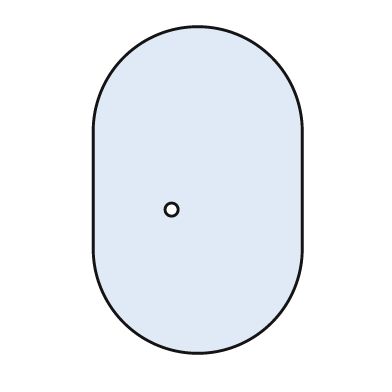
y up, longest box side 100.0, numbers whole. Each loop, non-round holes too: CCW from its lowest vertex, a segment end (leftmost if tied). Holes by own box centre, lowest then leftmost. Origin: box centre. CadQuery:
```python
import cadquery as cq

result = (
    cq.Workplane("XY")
    .moveTo(-32.0, -18.0)
    .threePointArc((0.0, -50.0), (32.0, -18.0))
    .lineTo(32.0, 18.0)
    .threePointArc((0.0, 50.0), (-32.0, 18.0))
    .close()
    .moveTo(-8.0, -6.0)
    .circle(2.0)
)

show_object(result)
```